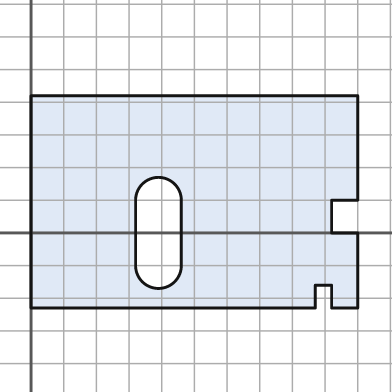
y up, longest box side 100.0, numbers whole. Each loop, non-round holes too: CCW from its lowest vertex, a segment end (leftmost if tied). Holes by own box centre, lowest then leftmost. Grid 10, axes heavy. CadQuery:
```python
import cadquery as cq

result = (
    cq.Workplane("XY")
    .moveTo(0.0, -23.0)
    .lineTo(87.0, -23.0)
    .lineTo(87.0, -16.0)
    .lineTo(92.0, -16.0)
    .lineTo(92.0, -23.0)
    .lineTo(100.0, -23.0)
    .lineTo(100.0, 0.0)
    .lineTo(92.0, 0.0)
    .lineTo(92.0, 10.0)
    .lineTo(100.0, 10.0)
    .lineTo(100.0, 42.0)
    .lineTo(0.0, 42.0)
    .close()
    .moveTo(32.0, -10.0)
    .threePointArc((39.0, -17.0), (46.0, -10.0))
    .lineTo(46.0, 10.0)
    .threePointArc((39.0, 17.0), (32.0, 10.0))
    .close()
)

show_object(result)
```